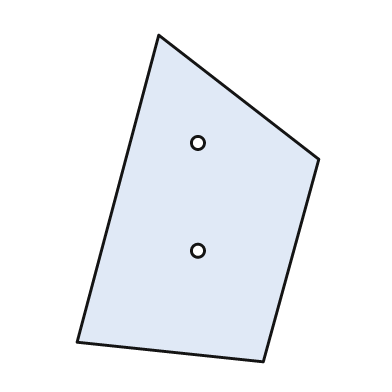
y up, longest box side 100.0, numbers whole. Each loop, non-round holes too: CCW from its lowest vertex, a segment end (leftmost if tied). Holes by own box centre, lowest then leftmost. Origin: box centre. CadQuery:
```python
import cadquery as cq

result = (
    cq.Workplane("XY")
    .moveTo(20.0, -50.0)
    .lineTo(37.0, 12.0)
    .lineTo(-12.0, 50.0)
    .lineTo(-37.0, -44.0)
    .close()
    .moveTo(0.0, -16.0)
    .circle(2.0)
    .moveTo(0.0, 17.0)
    .circle(2.0)
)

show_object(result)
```